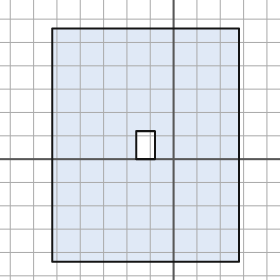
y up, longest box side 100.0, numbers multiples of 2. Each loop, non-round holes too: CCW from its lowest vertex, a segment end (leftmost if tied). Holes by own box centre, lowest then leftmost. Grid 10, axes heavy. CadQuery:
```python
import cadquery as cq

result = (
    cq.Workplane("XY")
    .moveTo(-52.0, -44.0)
    .lineTo(28.0, -44.0)
    .lineTo(28.0, 56.0)
    .lineTo(-52.0, 56.0)
    .close()
    .moveTo(-16.0, 0.0)
    .lineTo(-8.0, 0.0)
    .lineTo(-8.0, 12.0)
    .lineTo(-16.0, 12.0)
    .close()
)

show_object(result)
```